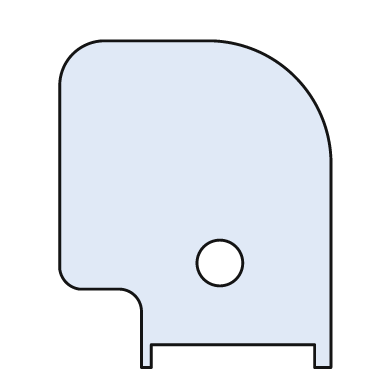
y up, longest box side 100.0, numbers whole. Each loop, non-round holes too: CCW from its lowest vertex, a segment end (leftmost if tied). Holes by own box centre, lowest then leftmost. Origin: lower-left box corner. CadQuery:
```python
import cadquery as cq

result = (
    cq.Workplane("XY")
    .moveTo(25.0, 0.0)
    .lineTo(28.0, 0.0)
    .lineTo(28.0, 7.0)
    .lineTo(78.0, 7.0)
    .lineTo(78.0, 0.0)
    .lineTo(83.0, 0.0)
    .lineTo(83.0, 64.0)
    .threePointArc((72.0, 89.0), (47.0, 100.0))
    .lineTo(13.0, 100.0)
    .threePointArc((4.0, 96.0), (0.0, 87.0))
    .lineTo(0.0, 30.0)
    .threePointArc((2.0, 26.0), (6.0, 24.0))
    .lineTo(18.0, 24.0)
    .threePointArc((23.0, 22.0), (25.0, 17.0))
    .close()
    .moveTo(49.0, 32.0)
    .circle(7.0)
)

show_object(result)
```